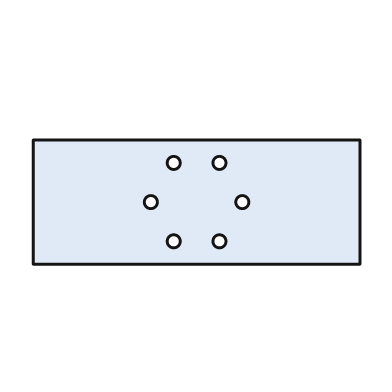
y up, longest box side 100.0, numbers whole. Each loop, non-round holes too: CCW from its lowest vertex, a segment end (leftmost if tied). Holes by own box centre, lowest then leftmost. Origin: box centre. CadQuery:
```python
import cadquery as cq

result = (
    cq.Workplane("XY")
    .moveTo(-50.0, -19.0)
    .lineTo(50.0, -19.0)
    .lineTo(50.0, 19.0)
    .lineTo(-50.0, 19.0)
    .close()
    .moveTo(-7.0, -12.0)
    .circle(2.0)
    .moveTo(7.0, -12.0)
    .circle(2.0)
    .moveTo(-14.0, 0.0)
    .circle(2.0)
    .moveTo(14.0, 0.0)
    .circle(2.0)
    .moveTo(-7.0, 12.0)
    .circle(2.0)
    .moveTo(7.0, 12.0)
    .circle(2.0)
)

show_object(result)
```